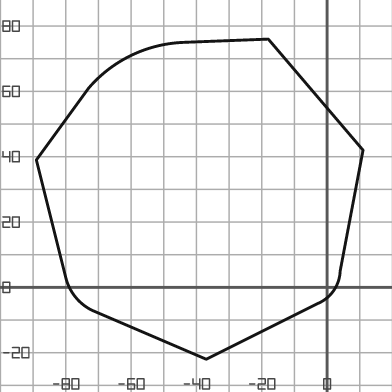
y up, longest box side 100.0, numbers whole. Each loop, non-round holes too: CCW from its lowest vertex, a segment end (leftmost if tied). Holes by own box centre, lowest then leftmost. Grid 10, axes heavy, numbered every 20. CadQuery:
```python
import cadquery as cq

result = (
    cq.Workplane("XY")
    .moveTo(-37.0, -22.0)
    .lineTo(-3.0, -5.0)
    .threePointArc((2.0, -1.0), (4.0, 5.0))
    .lineTo(11.0, 42.0)
    .lineTo(-18.0, 76.0)
    .lineTo(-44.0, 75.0)
    .threePointArc((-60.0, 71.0), (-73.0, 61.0))
    .lineTo(-89.0, 39.0)
    .lineTo(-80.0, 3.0)
    .threePointArc((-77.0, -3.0), (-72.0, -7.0))
    .close()
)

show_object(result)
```